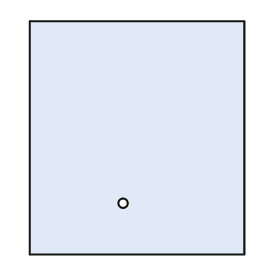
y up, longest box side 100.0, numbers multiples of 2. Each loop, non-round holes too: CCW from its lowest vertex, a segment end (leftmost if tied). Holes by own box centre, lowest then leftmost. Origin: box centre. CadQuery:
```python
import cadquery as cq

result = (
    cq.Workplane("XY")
    .moveTo(-46.0, -50.0)
    .lineTo(46.0, -50.0)
    .lineTo(46.0, 50.0)
    .lineTo(-46.0, 50.0)
    .close()
    .moveTo(-6.0, -28.0)
    .circle(2.0)
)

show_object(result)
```